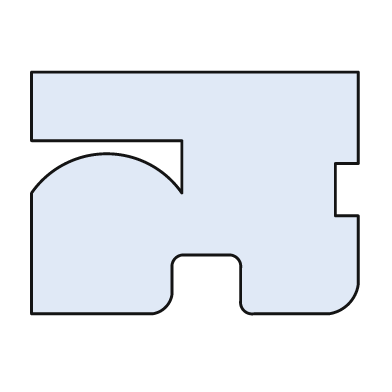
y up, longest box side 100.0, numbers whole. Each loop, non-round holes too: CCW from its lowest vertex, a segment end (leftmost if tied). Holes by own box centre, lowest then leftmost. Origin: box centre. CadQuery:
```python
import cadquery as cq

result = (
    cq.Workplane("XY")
    .moveTo(-50.0, -37.0)
    .lineTo(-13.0, -37.0)
    .threePointArc((-9.0, -35.0), (-7.0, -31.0))
    .lineTo(-7.0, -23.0)
    .threePointArc((-6.0, -20.0), (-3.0, -19.0))
    .lineTo(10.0, -19.0)
    .threePointArc((13.0, -20.0), (14.0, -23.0))
    .lineTo(14.0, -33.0)
    .threePointArc((15.0, -36.0), (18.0, -37.0))
    .lineTo(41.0, -37.0)
    .threePointArc((47.0, -34.0), (50.0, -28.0))
    .lineTo(50.0, -7.0)
    .lineTo(43.0, -7.0)
    .lineTo(43.0, 9.0)
    .lineTo(50.0, 9.0)
    .lineTo(50.0, 37.0)
    .lineTo(-50.0, 37.0)
    .lineTo(-50.0, 16.0)
    .lineTo(-4.0, 16.0)
    .lineTo(-4.0, 0.0)
    .threePointArc((-27.0, 12.0), (-50.0, 0.0))
    .close()
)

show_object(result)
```